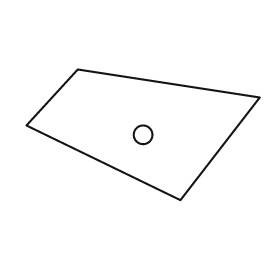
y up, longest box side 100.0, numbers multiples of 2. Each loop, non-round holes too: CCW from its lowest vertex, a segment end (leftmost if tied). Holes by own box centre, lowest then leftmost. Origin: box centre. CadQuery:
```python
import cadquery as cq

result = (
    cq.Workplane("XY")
    .moveTo(16.0, -28.0)
    .lineTo(50.0, 16.0)
    .lineTo(-28.0, 28.0)
    .lineTo(-50.0, 4.0)
    .close()
    .moveTo(0.0, 0.0)
    .circle(4.0)
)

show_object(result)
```